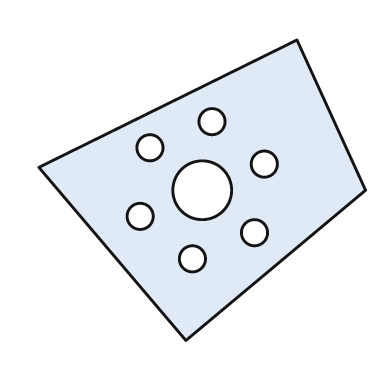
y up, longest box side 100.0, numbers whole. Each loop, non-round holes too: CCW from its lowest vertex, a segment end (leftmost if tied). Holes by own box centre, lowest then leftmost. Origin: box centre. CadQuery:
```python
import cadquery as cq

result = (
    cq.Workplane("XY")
    .moveTo(-5.0, -46.0)
    .lineTo(50.0, 0.0)
    .lineTo(29.0, 46.0)
    .lineTo(-50.0, 7.0)
    .close()
    .moveTo(-3.0, -21.0)
    .circle(4.0)
    .moveTo(16.0, -13.0)
    .circle(4.0)
    .moveTo(-19.0, -8.0)
    .circle(4.0)
    .moveTo(0.0, 0.0)
    .circle(9.0)
    .moveTo(19.0, 8.0)
    .circle(4.0)
    .moveTo(-16.0, 13.0)
    .circle(4.0)
    .moveTo(3.0, 21.0)
    .circle(4.0)
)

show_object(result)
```